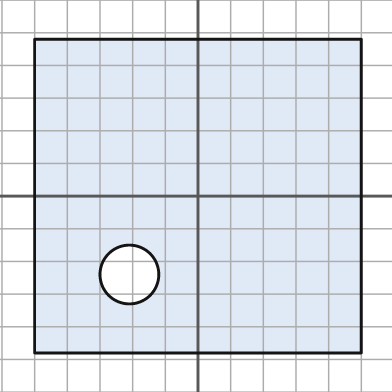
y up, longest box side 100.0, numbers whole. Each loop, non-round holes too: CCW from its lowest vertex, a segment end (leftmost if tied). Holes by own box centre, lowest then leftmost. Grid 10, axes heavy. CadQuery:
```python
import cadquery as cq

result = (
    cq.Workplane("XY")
    .moveTo(-50.0, -48.0)
    .lineTo(50.0, -48.0)
    .lineTo(50.0, 48.0)
    .lineTo(-50.0, 48.0)
    .close()
    .moveTo(-21.0, -24.0)
    .circle(9.0)
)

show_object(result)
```